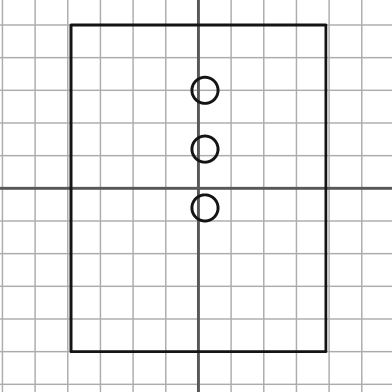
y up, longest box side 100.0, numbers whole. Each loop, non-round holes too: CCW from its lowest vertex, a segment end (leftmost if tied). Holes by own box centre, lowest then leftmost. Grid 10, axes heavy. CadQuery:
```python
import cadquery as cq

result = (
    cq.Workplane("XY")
    .moveTo(-39.0, -50.0)
    .lineTo(39.0, -50.0)
    .lineTo(39.0, 50.0)
    .lineTo(-39.0, 50.0)
    .close()
    .moveTo(2.0, -6.0)
    .circle(4.0)
    .moveTo(2.0, 12.0)
    .circle(4.0)
    .moveTo(2.0, 30.0)
    .circle(4.0)
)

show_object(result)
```